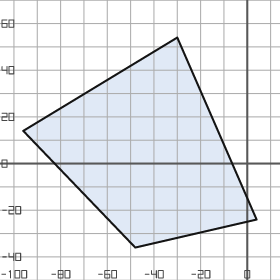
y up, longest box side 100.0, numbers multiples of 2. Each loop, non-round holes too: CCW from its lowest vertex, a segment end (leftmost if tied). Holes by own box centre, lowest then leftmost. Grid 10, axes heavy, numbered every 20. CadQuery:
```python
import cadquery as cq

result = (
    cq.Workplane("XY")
    .moveTo(-48.0, -36.0)
    .lineTo(4.0, -24.0)
    .lineTo(-30.0, 54.0)
    .lineTo(-96.0, 14.0)
    .close()
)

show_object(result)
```